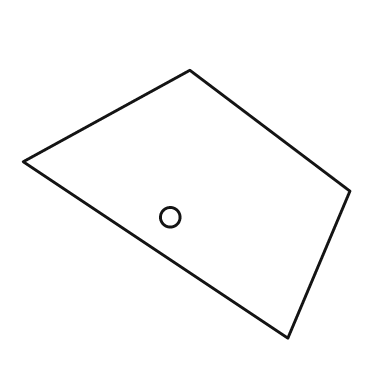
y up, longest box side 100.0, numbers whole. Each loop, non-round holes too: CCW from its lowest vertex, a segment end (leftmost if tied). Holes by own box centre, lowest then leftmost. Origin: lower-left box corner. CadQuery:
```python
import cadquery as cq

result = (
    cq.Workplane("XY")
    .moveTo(81.0, 0.0)
    .lineTo(100.0, 45.0)
    .lineTo(51.0, 82.0)
    .lineTo(0.0, 54.0)
    .close()
    .moveTo(45.0, 37.0)
    .circle(3.0)
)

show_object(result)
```